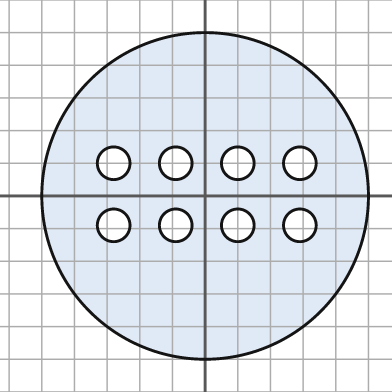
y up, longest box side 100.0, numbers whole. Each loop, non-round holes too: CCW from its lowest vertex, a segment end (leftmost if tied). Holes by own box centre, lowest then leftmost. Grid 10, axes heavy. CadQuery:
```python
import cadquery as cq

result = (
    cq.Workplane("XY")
    .moveTo(0.0, 0.0)
    .circle(50.0)
    .moveTo(-28.0, -9.0)
    .circle(5.0)
    .moveTo(-9.0, -9.0)
    .circle(5.0)
    .moveTo(10.0, -9.0)
    .circle(5.0)
    .moveTo(29.0, -9.0)
    .circle(5.0)
    .moveTo(-28.0, 10.0)
    .circle(5.0)
    .moveTo(-9.0, 10.0)
    .circle(5.0)
    .moveTo(10.0, 10.0)
    .circle(5.0)
    .moveTo(29.0, 10.0)
    .circle(5.0)
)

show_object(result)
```